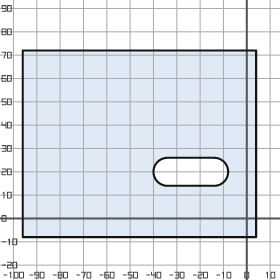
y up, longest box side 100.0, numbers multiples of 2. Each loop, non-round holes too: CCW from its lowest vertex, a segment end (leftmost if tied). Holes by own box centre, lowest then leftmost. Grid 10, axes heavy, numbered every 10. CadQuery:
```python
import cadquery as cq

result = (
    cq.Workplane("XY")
    .moveTo(-96.0, -8.0)
    .lineTo(4.0, -8.0)
    .lineTo(4.0, 72.0)
    .lineTo(-96.0, 72.0)
    .close()
    .moveTo(-34.0, 14.0)
    .lineTo(-14.0, 14.0)
    .threePointArc((-8.0, 20.0), (-14.0, 26.0))
    .lineTo(-34.0, 26.0)
    .threePointArc((-40.0, 20.0), (-34.0, 14.0))
    .close()
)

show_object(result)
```